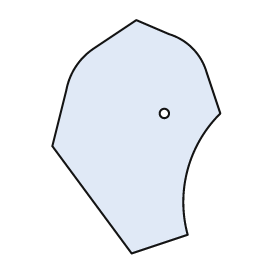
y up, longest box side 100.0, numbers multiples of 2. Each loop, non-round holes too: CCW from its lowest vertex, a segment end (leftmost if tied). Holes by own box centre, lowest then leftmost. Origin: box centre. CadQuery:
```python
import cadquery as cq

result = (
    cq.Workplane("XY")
    .moveTo(-2.0, -50.0)
    .lineTo(22.0, -42.0)
    .threePointArc((22.0, -14.0), (36.0, 10.0))
    .lineTo(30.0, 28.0)
    .threePointArc((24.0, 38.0), (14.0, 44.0))
    .lineTo(0.0, 50.0)
    .lineTo(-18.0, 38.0)
    .threePointArc((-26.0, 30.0), (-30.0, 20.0))
    .lineTo(-36.0, -4.0)
    .close()
    .moveTo(12.0, 10.0)
    .circle(2.0)
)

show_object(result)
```